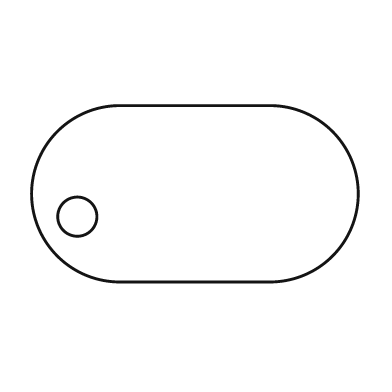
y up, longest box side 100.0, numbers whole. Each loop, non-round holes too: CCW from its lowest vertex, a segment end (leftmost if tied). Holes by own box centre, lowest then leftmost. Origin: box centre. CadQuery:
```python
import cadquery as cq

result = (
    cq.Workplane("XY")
    .moveTo(-23.0, -27.0)
    .lineTo(23.0, -27.0)
    .threePointArc((50.0, 0.0), (23.0, 27.0))
    .lineTo(-23.0, 27.0)
    .threePointArc((-50.0, 0.0), (-23.0, -27.0))
    .close()
    .moveTo(-36.0, -7.0)
    .circle(6.0)
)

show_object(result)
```